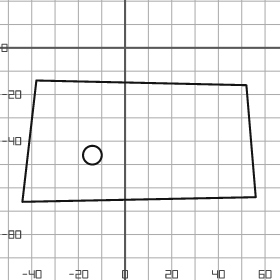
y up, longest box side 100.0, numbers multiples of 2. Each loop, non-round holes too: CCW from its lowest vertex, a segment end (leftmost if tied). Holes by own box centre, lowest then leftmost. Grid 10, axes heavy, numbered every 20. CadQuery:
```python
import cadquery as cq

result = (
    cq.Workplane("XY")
    .moveTo(-44.0, -66.0)
    .lineTo(56.0, -64.0)
    .lineTo(52.0, -16.0)
    .lineTo(-38.0, -14.0)
    .close()
    .moveTo(-14.0, -46.0)
    .circle(4.0)
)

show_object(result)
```